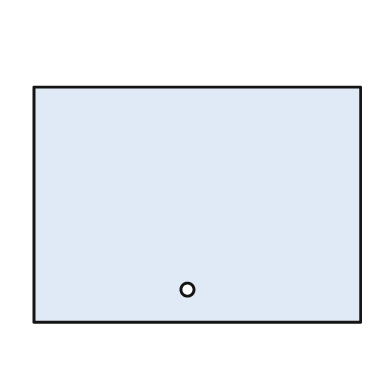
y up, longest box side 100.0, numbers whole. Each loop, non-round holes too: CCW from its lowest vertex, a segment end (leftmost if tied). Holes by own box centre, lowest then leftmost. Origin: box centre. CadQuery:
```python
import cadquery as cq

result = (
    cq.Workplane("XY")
    .moveTo(-50.0, -36.0)
    .lineTo(50.0, -36.0)
    .lineTo(50.0, 36.0)
    .lineTo(-50.0, 36.0)
    .close()
    .moveTo(-3.0, -26.0)
    .circle(2.0)
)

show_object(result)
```